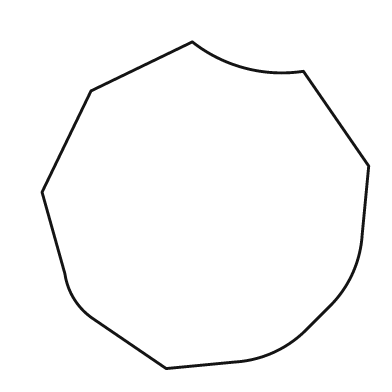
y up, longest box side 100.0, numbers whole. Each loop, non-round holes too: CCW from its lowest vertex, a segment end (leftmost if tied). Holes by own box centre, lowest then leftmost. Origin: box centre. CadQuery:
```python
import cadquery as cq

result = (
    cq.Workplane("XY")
    .moveTo(-12.0, -50.0)
    .lineTo(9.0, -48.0)
    .threePointArc((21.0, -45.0), (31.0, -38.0))
    .lineTo(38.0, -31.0)
    .threePointArc((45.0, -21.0), (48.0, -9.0))
    .lineTo(50.0, 12.0)
    .lineTo(30.0, 41.0)
    .threePointArc((12.0, 42.0), (-4.0, 50.0))
    .lineTo(-35.0, 35.0)
    .lineTo(-50.0, 4.0)
    .lineTo(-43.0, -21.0)
    .threePointArc((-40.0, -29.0), (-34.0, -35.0))
    .close()
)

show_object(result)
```